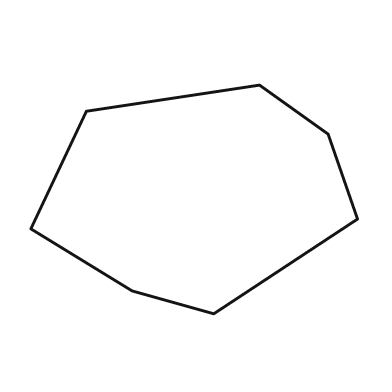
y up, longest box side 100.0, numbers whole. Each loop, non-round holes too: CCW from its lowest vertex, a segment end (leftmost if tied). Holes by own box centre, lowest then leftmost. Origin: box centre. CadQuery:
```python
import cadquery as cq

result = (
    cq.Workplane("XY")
    .moveTo(6.0, -35.0)
    .lineTo(50.0, -6.0)
    .lineTo(41.0, 20.0)
    .lineTo(20.0, 35.0)
    .lineTo(-33.0, 27.0)
    .lineTo(-50.0, -9.0)
    .lineTo(-19.0, -28.0)
    .close()
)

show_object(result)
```